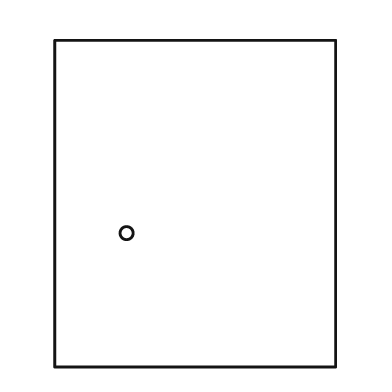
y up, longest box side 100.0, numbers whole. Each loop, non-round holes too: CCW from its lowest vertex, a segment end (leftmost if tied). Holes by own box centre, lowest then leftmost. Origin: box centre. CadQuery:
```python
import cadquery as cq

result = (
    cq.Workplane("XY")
    .moveTo(-43.0, -50.0)
    .lineTo(43.0, -50.0)
    .lineTo(43.0, 50.0)
    .lineTo(-43.0, 50.0)
    .close()
    .moveTo(-21.0, -9.0)
    .circle(2.0)
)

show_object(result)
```